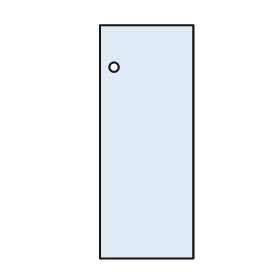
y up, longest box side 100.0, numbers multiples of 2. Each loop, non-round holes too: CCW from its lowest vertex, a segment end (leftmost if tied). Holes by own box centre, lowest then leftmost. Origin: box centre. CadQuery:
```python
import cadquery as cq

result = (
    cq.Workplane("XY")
    .moveTo(-20.0, -50.0)
    .lineTo(20.0, -50.0)
    .lineTo(20.0, 50.0)
    .lineTo(-20.0, 50.0)
    .close()
    .moveTo(-14.0, 32.0)
    .circle(2.0)
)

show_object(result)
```